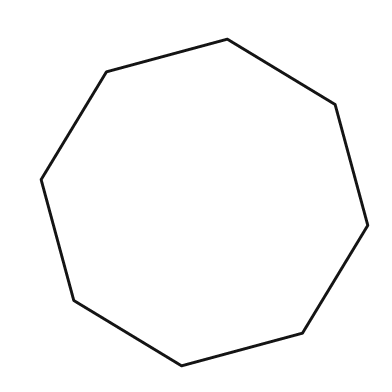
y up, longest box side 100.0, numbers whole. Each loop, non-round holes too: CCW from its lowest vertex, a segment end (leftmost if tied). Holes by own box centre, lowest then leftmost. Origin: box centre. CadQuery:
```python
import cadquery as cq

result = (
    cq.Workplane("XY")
    .moveTo(-7.0, -50.0)
    .lineTo(30.0, -40.0)
    .lineTo(50.0, -7.0)
    .lineTo(40.0, 30.0)
    .lineTo(7.0, 50.0)
    .lineTo(-30.0, 40.0)
    .lineTo(-50.0, 7.0)
    .lineTo(-40.0, -30.0)
    .close()
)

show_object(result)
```